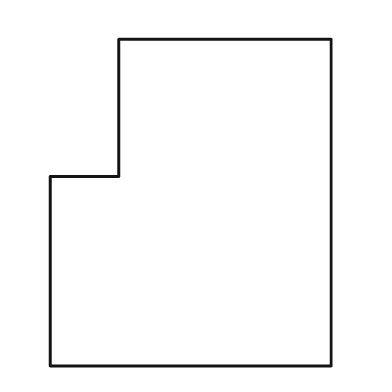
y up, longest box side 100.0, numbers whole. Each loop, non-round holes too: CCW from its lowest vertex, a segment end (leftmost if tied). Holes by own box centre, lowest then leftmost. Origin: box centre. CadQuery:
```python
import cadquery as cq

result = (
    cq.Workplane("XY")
    .moveTo(-43.0, -50.0)
    .lineTo(43.0, -50.0)
    .lineTo(43.0, 50.0)
    .lineTo(-22.0, 50.0)
    .lineTo(-22.0, 8.0)
    .lineTo(-43.0, 8.0)
    .close()
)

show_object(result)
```